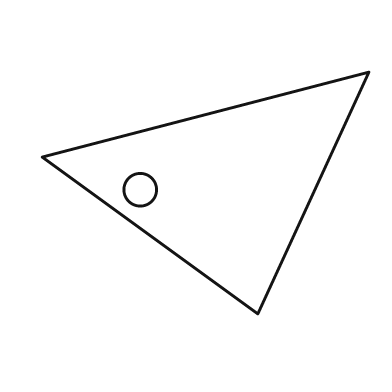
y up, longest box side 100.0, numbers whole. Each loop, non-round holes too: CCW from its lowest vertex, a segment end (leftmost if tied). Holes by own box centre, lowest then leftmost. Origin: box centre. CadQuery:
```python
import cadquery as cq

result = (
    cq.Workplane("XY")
    .moveTo(16.0, -37.0)
    .lineTo(50.0, 37.0)
    .lineTo(-50.0, 11.0)
    .close()
    .moveTo(-20.0, 1.0)
    .circle(5.0)
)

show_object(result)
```